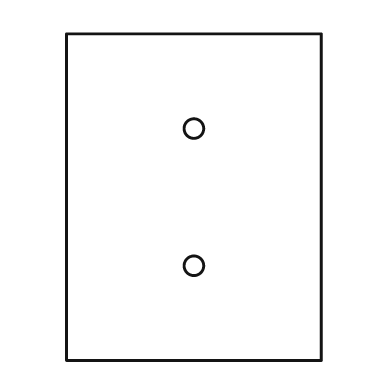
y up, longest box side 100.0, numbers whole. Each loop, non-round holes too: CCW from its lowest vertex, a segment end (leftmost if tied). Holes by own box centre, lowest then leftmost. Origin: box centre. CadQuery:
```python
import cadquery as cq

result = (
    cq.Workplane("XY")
    .moveTo(-39.0, -50.0)
    .lineTo(39.0, -50.0)
    .lineTo(39.0, 50.0)
    .lineTo(-39.0, 50.0)
    .close()
    .moveTo(0.0, -21.0)
    .circle(3.0)
    .moveTo(0.0, 21.0)
    .circle(3.0)
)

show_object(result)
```